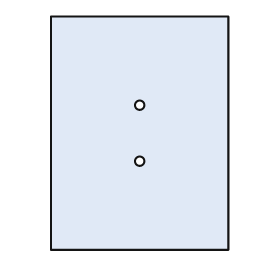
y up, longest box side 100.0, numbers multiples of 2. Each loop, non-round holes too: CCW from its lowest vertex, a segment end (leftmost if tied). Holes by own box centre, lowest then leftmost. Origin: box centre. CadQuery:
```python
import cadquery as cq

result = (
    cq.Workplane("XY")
    .moveTo(-38.0, -50.0)
    .lineTo(38.0, -50.0)
    .lineTo(38.0, 50.0)
    .lineTo(-38.0, 50.0)
    .close()
    .moveTo(0.0, -12.0)
    .circle(2.0)
    .moveTo(0.0, 12.0)
    .circle(2.0)
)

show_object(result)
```